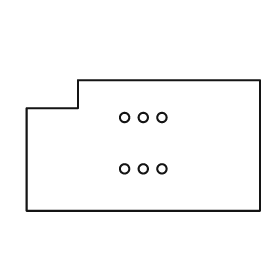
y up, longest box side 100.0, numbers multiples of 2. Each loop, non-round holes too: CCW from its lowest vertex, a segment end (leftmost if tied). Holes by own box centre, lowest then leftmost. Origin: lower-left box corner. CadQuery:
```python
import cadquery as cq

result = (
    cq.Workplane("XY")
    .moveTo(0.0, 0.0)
    .lineTo(100.0, 0.0)
    .lineTo(100.0, 56.0)
    .lineTo(22.0, 56.0)
    .lineTo(22.0, 44.0)
    .lineTo(0.0, 44.0)
    .close()
    .moveTo(42.0, 18.0)
    .circle(2.0)
    .moveTo(50.0, 18.0)
    .circle(2.0)
    .moveTo(58.0, 18.0)
    .circle(2.0)
    .moveTo(42.0, 40.0)
    .circle(2.0)
    .moveTo(50.0, 40.0)
    .circle(2.0)
    .moveTo(58.0, 40.0)
    .circle(2.0)
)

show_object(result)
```